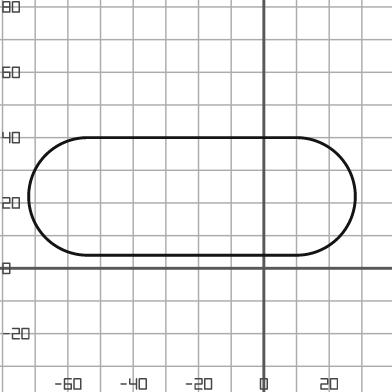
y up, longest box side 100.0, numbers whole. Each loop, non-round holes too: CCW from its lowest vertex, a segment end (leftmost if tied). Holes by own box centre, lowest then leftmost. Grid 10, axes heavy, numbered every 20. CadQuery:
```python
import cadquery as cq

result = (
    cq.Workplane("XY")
    .moveTo(-54.0, 4.0)
    .lineTo(10.0, 4.0)
    .threePointArc((28.0, 22.0), (10.0, 40.0))
    .lineTo(-54.0, 40.0)
    .threePointArc((-72.0, 22.0), (-54.0, 4.0))
    .close()
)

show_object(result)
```